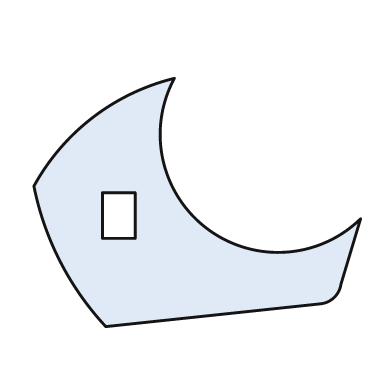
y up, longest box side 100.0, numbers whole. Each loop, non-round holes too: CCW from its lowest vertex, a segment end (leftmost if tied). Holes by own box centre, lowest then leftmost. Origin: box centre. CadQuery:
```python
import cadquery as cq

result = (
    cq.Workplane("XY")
    .moveTo(-28.0, -38.0)
    .lineTo(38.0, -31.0)
    .threePointArc((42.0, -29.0), (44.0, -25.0))
    .lineTo(50.0, -5.0)
    .threePointArc((3.0, -8.0), (-7.0, 38.0))
    .threePointArc((-32.0, 26.0), (-50.0, 5.0))
    .threePointArc((-42.0, -18.0), (-28.0, -38.0))
    .close()
    .moveTo(-29.0, -11.0)
    .lineTo(-19.0, -11.0)
    .lineTo(-19.0, 3.0)
    .lineTo(-29.0, 3.0)
    .close()
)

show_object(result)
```